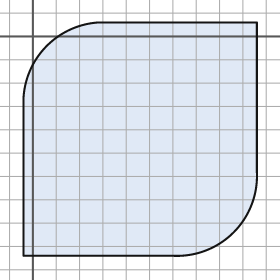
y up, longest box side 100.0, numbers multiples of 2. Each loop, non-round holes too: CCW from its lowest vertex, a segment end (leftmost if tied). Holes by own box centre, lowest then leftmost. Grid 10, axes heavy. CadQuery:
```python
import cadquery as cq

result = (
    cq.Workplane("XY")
    .moveTo(-4.0, -94.0)
    .lineTo(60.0, -94.0)
    .threePointArc((86.0, -84.0), (96.0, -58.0))
    .lineTo(96.0, 6.0)
    .lineTo(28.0, 6.0)
    .threePointArc((6.0, -4.0), (-4.0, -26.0))
    .close()
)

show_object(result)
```